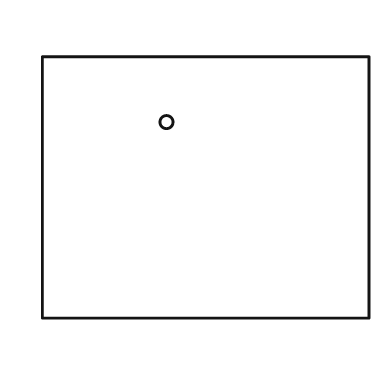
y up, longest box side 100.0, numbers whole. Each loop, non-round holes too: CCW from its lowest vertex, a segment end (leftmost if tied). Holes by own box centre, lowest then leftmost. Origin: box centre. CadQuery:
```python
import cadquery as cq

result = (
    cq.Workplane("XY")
    .moveTo(-50.0, -40.0)
    .lineTo(50.0, -40.0)
    .lineTo(50.0, 40.0)
    .lineTo(-50.0, 40.0)
    .close()
    .moveTo(-12.0, 20.0)
    .circle(2.0)
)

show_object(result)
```